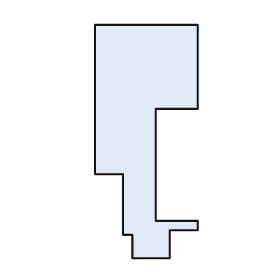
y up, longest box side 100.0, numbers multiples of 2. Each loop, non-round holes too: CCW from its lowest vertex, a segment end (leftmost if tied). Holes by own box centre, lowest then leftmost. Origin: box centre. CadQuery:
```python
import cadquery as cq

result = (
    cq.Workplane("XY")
    .moveTo(-6.0, -50.0)
    .lineTo(10.0, -50.0)
    .lineTo(10.0, -38.0)
    .lineTo(22.0, -38.0)
    .lineTo(22.0, -34.0)
    .lineTo(4.0, -34.0)
    .lineTo(4.0, 14.0)
    .lineTo(22.0, 14.0)
    .lineTo(22.0, 50.0)
    .lineTo(-22.0, 50.0)
    .lineTo(-22.0, -14.0)
    .lineTo(-10.0, -14.0)
    .lineTo(-10.0, -40.0)
    .lineTo(-6.0, -40.0)
    .close()
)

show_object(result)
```